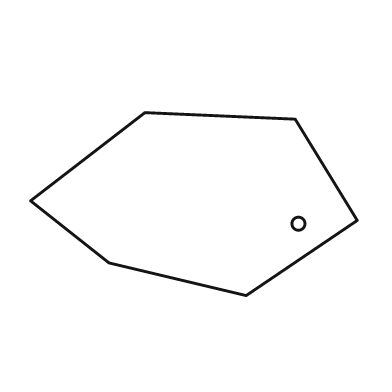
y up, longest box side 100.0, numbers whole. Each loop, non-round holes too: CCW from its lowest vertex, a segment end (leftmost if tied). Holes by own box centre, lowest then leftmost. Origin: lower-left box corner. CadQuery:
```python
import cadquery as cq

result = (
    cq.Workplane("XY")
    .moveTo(66.0, 0.0)
    .lineTo(100.0, 23.0)
    .lineTo(81.0, 54.0)
    .lineTo(35.0, 56.0)
    .lineTo(0.0, 29.0)
    .lineTo(24.0, 10.0)
    .close()
    .moveTo(82.0, 22.0)
    .circle(2.0)
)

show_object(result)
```